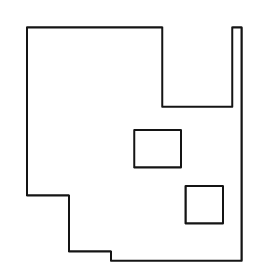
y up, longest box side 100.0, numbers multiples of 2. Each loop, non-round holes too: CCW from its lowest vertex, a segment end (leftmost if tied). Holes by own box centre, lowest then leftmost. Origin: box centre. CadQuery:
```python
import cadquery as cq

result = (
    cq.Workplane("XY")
    .moveTo(-10.0, -50.0)
    .lineTo(46.0, -50.0)
    .lineTo(46.0, 50.0)
    .lineTo(42.0, 50.0)
    .lineTo(42.0, 16.0)
    .lineTo(12.0, 16.0)
    .lineTo(12.0, 50.0)
    .lineTo(-46.0, 50.0)
    .lineTo(-46.0, -22.0)
    .lineTo(-28.0, -22.0)
    .lineTo(-28.0, -46.0)
    .lineTo(-10.0, -46.0)
    .close()
    .moveTo(22.0, -34.0)
    .lineTo(38.0, -34.0)
    .lineTo(38.0, -18.0)
    .lineTo(22.0, -18.0)
    .close()
    .moveTo(0.0, -10.0)
    .lineTo(20.0, -10.0)
    .lineTo(20.0, 6.0)
    .lineTo(0.0, 6.0)
    .close()
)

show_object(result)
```